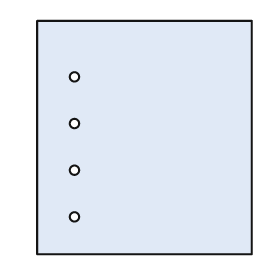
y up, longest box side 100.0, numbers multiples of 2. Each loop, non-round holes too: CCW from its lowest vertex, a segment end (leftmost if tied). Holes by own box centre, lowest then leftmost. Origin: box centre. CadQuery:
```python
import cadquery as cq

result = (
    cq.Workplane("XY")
    .moveTo(-46.0, -50.0)
    .lineTo(46.0, -50.0)
    .lineTo(46.0, 50.0)
    .lineTo(-46.0, 50.0)
    .close()
    .moveTo(-30.0, -34.0)
    .circle(2.0)
    .moveTo(-30.0, -14.0)
    .circle(2.0)
    .moveTo(-30.0, 6.0)
    .circle(2.0)
    .moveTo(-30.0, 26.0)
    .circle(2.0)
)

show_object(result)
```